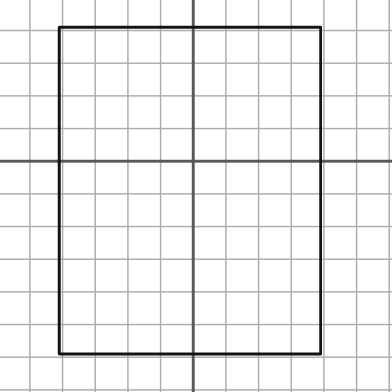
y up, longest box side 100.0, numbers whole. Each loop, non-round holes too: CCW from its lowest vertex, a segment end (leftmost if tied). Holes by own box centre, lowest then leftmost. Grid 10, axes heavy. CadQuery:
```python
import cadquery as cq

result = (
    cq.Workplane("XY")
    .moveTo(-41.0, -59.0)
    .lineTo(39.0, -59.0)
    .lineTo(39.0, 41.0)
    .lineTo(-41.0, 41.0)
    .close()
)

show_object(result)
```